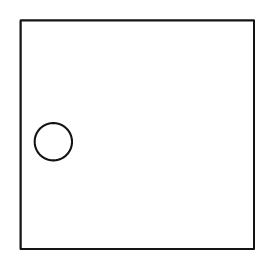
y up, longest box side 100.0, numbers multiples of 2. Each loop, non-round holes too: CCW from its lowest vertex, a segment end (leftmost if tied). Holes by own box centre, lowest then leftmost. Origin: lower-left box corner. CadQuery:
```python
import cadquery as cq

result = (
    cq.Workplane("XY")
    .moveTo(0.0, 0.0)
    .lineTo(100.0, 0.0)
    .lineTo(100.0, 98.0)
    .lineTo(0.0, 98.0)
    .close()
    .moveTo(14.0, 46.0)
    .circle(8.0)
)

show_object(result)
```